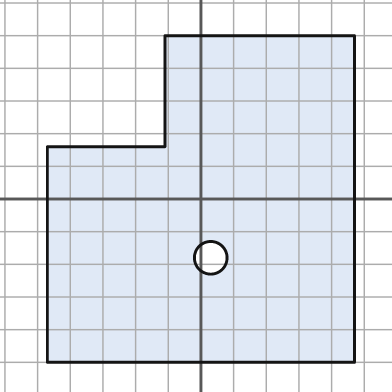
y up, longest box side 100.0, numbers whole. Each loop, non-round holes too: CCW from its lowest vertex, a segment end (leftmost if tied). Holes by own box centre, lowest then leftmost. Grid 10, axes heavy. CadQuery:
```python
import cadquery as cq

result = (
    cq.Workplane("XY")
    .moveTo(-47.0, -50.0)
    .lineTo(47.0, -50.0)
    .lineTo(47.0, 50.0)
    .lineTo(-11.0, 50.0)
    .lineTo(-11.0, 16.0)
    .lineTo(-47.0, 16.0)
    .close()
    .moveTo(3.0, -18.0)
    .circle(5.0)
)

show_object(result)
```